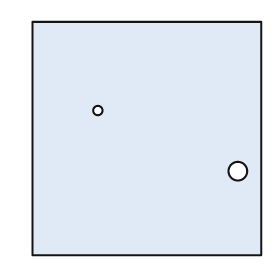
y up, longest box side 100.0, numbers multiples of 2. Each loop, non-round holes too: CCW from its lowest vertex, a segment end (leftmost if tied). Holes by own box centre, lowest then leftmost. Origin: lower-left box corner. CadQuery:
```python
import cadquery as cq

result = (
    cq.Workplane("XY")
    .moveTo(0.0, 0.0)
    .lineTo(98.0, 0.0)
    .lineTo(98.0, 100.0)
    .lineTo(0.0, 100.0)
    .close()
    .moveTo(88.0, 36.0)
    .circle(4.0)
    .moveTo(28.0, 62.0)
    .circle(2.0)
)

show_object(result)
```